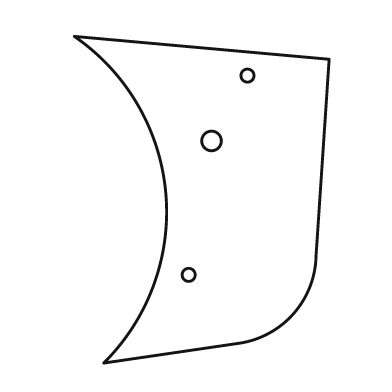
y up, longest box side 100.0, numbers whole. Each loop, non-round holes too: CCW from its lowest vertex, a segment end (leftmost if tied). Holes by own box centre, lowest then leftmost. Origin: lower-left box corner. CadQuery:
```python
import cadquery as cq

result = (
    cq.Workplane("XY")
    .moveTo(9.0, 0.0)
    .lineTo(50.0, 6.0)
    .threePointArc((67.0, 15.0), (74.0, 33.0))
    .lineTo(78.0, 93.0)
    .lineTo(0.0, 100.0)
    .threePointArc((28.0, 52.0), (9.0, 0.0))
    .close()
    .moveTo(35.0, 27.0)
    .circle(2.0)
    .moveTo(42.0, 68.0)
    .circle(3.0)
    .moveTo(53.0, 88.0)
    .circle(2.0)
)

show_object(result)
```